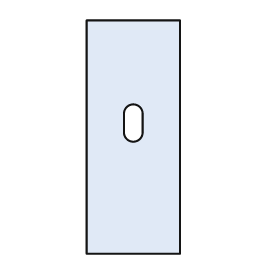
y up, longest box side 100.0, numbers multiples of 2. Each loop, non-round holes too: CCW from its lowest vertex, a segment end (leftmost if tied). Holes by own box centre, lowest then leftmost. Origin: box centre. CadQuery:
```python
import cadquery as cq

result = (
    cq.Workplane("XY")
    .moveTo(-20.0, -50.0)
    .lineTo(20.0, -50.0)
    .lineTo(20.0, 50.0)
    .lineTo(-20.0, 50.0)
    .close()
    .moveTo(-4.0, 2.0)
    .threePointArc((0.0, -2.0), (4.0, 2.0))
    .lineTo(4.0, 10.0)
    .threePointArc((0.0, 14.0), (-4.0, 10.0))
    .close()
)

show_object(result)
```